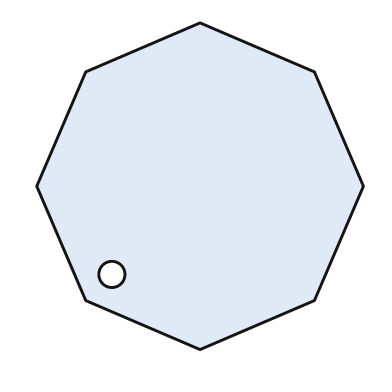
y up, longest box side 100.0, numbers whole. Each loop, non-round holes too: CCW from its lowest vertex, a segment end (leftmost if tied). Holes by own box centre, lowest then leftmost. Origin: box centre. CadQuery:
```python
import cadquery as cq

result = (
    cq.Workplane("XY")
    .moveTo(0.0, -50.0)
    .lineTo(35.0, -35.0)
    .lineTo(50.0, 0.0)
    .lineTo(35.0, 35.0)
    .lineTo(0.0, 50.0)
    .lineTo(-35.0, 35.0)
    .lineTo(-50.0, 0.0)
    .lineTo(-35.0, -35.0)
    .close()
    .moveTo(-27.0, -27.0)
    .circle(4.0)
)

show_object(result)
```